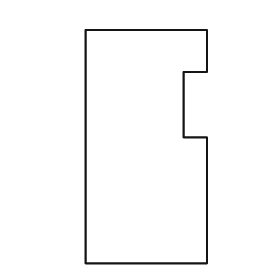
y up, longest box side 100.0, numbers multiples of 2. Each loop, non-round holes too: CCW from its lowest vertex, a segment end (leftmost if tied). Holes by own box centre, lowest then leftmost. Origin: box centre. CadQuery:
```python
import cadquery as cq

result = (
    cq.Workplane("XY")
    .moveTo(-26.0, -50.0)
    .lineTo(26.0, -50.0)
    .lineTo(26.0, 4.0)
    .lineTo(16.0, 4.0)
    .lineTo(16.0, 32.0)
    .lineTo(26.0, 32.0)
    .lineTo(26.0, 50.0)
    .lineTo(-26.0, 50.0)
    .close()
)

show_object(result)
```